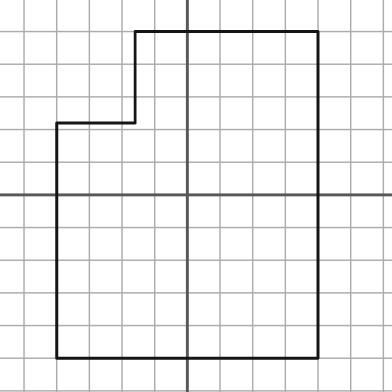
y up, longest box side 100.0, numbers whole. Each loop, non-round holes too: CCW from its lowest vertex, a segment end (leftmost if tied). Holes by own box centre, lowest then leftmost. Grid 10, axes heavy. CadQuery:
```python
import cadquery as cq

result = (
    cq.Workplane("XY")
    .moveTo(-40.0, -50.0)
    .lineTo(40.0, -50.0)
    .lineTo(40.0, 50.0)
    .lineTo(-16.0, 50.0)
    .lineTo(-16.0, 22.0)
    .lineTo(-40.0, 22.0)
    .close()
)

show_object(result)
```